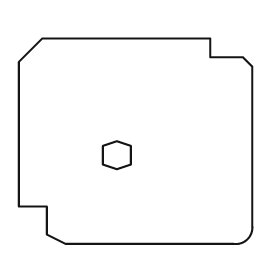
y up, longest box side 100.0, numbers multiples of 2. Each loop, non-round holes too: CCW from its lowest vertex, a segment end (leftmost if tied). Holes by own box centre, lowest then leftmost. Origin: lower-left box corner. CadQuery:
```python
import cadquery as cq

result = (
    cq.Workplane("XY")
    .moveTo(20.0, 0.0)
    .lineTo(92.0, 0.0)
    .threePointArc((98.0, 2.0), (100.0, 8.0))
    .lineTo(100.0, 76.0)
    .lineTo(96.0, 80.0)
    .lineTo(82.0, 80.0)
    .lineTo(82.0, 88.0)
    .lineTo(10.0, 88.0)
    .lineTo(0.0, 78.0)
    .lineTo(0.0, 16.0)
    .lineTo(12.0, 16.0)
    .lineTo(12.0, 4.0)
    .close()
    .moveTo(42.0, 32.0)
    .lineTo(48.0, 34.0)
    .lineTo(48.0, 42.0)
    .lineTo(42.0, 44.0)
    .lineTo(36.0, 42.0)
    .lineTo(36.0, 34.0)
    .close()
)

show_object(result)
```